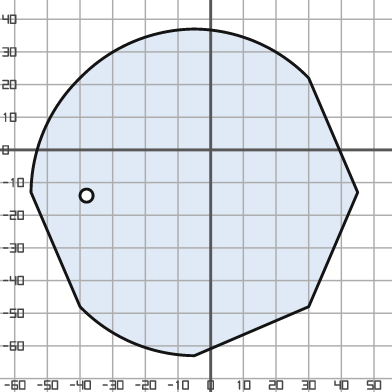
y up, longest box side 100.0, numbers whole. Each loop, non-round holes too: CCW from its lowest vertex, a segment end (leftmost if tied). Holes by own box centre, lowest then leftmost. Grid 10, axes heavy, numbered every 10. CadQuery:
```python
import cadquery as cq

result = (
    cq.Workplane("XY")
    .moveTo(-5.0, -63.0)
    .lineTo(30.0, -48.0)
    .lineTo(45.0, -13.0)
    .lineTo(30.0, 22.0)
    .threePointArc((14.0, 33.0), (-5.0, 37.0))
    .threePointArc((-24.0, 33.0), (-40.0, 22.0))
    .threePointArc((-51.0, 6.0), (-55.0, -13.0))
    .lineTo(-40.0, -48.0)
    .threePointArc((-24.0, -59.0), (-5.0, -63.0))
    .close()
    .moveTo(-38.0, -14.0)
    .circle(2.0)
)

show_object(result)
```